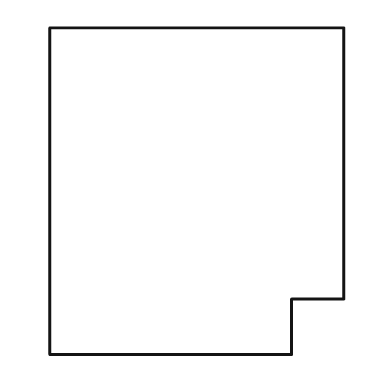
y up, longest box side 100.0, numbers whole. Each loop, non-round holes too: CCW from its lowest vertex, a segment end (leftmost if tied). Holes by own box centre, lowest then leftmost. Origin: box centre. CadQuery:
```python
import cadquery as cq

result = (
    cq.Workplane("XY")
    .moveTo(-45.0, -50.0)
    .lineTo(29.0, -50.0)
    .lineTo(29.0, -33.0)
    .lineTo(45.0, -33.0)
    .lineTo(45.0, 50.0)
    .lineTo(-45.0, 50.0)
    .close()
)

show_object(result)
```